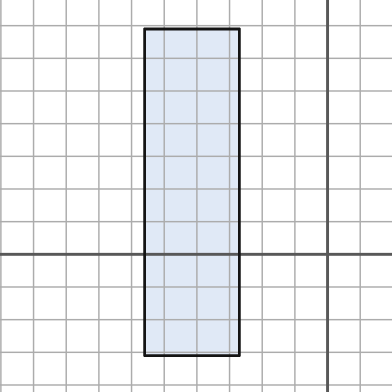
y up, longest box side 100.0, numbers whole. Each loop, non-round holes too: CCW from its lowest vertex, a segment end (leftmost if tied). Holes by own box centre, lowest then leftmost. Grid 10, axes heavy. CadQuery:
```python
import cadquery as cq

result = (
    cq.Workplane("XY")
    .moveTo(-56.0, -31.0)
    .lineTo(-27.0, -31.0)
    .lineTo(-27.0, 69.0)
    .lineTo(-56.0, 69.0)
    .close()
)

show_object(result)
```